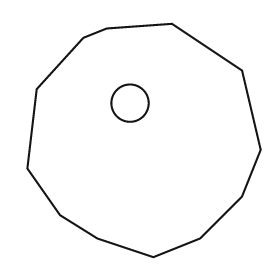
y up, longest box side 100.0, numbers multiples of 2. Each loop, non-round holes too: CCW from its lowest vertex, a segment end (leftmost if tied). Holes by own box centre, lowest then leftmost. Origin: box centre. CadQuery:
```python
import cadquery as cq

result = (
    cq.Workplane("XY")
    .moveTo(4.0, -50.0)
    .lineTo(24.0, -42.0)
    .lineTo(42.0, -24.0)
    .lineTo(50.0, -4.0)
    .lineTo(42.0, 30.0)
    .lineTo(12.0, 50.0)
    .lineTo(-16.0, 48.0)
    .lineTo(-26.0, 44.0)
    .lineTo(-46.0, 22.0)
    .lineTo(-50.0, -12.0)
    .lineTo(-36.0, -32.0)
    .lineTo(-20.0, -42.0)
    .close()
    .moveTo(-6.0, 16.0)
    .circle(8.0)
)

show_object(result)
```